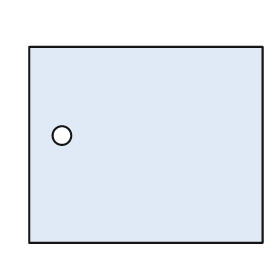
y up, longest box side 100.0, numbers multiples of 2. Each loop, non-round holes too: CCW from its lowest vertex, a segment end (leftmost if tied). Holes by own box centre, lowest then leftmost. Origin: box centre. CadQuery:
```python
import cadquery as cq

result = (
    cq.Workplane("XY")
    .moveTo(-50.0, -42.0)
    .lineTo(50.0, -42.0)
    .lineTo(50.0, 42.0)
    .lineTo(-50.0, 42.0)
    .close()
    .moveTo(-36.0, 4.0)
    .circle(4.0)
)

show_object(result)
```